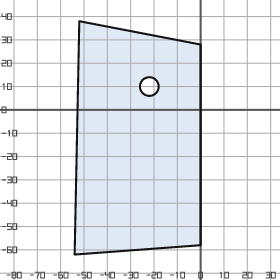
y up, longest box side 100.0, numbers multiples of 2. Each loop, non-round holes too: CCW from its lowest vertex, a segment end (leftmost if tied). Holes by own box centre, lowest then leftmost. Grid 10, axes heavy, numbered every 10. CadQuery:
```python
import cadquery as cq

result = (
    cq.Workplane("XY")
    .moveTo(-54.0, -62.0)
    .lineTo(0.0, -58.0)
    .lineTo(0.0, 28.0)
    .lineTo(-52.0, 38.0)
    .close()
    .moveTo(-22.0, 10.0)
    .circle(4.0)
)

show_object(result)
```